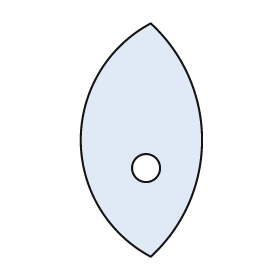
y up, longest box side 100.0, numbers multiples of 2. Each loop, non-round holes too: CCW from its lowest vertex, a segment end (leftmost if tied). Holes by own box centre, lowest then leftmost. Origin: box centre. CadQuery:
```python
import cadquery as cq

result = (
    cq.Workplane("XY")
    .moveTo(4.0, -50.0)
    .threePointArc((26.0, 0.0), (4.0, 50.0))
    .threePointArc((-26.0, 0.0), (4.0, -50.0))
    .close()
    .moveTo(2.0, -12.0)
    .circle(6.0)
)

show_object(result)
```